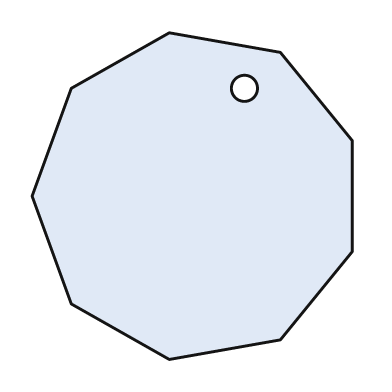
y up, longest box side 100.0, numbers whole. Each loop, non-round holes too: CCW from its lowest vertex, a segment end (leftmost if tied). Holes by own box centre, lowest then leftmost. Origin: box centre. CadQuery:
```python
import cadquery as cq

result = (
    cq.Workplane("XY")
    .moveTo(-7.0, -50.0)
    .lineTo(27.0, -44.0)
    .lineTo(49.0, -17.0)
    .lineTo(49.0, 17.0)
    .lineTo(27.0, 44.0)
    .lineTo(-7.0, 50.0)
    .lineTo(-37.0, 33.0)
    .lineTo(-49.0, 0.0)
    .lineTo(-37.0, -33.0)
    .close()
    .moveTo(16.0, 33.0)
    .circle(4.0)
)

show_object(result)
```